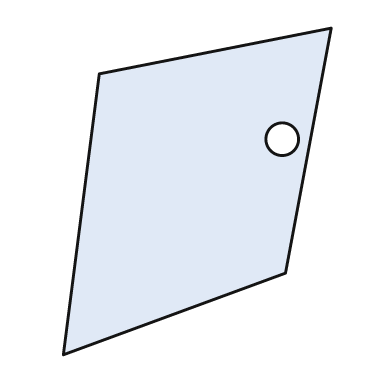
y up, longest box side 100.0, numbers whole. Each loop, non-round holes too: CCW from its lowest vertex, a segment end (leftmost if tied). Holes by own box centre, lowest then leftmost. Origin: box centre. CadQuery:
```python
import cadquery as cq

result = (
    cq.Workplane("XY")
    .moveTo(-41.0, -50.0)
    .lineTo(27.0, -25.0)
    .lineTo(41.0, 50.0)
    .lineTo(-30.0, 36.0)
    .close()
    .moveTo(26.0, 16.0)
    .circle(5.0)
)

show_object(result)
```